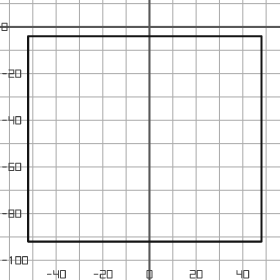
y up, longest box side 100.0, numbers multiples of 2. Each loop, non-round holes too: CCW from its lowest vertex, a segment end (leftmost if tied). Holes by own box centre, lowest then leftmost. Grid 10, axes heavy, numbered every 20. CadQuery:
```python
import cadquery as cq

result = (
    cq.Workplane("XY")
    .moveTo(-52.0, -92.0)
    .lineTo(48.0, -92.0)
    .lineTo(48.0, -4.0)
    .lineTo(-52.0, -4.0)
    .close()
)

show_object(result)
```